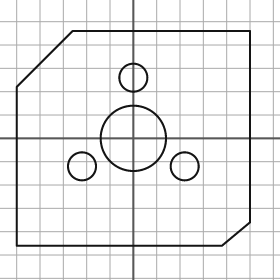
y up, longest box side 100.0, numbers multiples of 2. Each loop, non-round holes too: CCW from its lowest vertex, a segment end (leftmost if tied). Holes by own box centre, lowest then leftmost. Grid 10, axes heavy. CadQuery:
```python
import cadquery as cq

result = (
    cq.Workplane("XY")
    .moveTo(-50.0, -46.0)
    .lineTo(38.0, -46.0)
    .lineTo(50.0, -36.0)
    .lineTo(50.0, 46.0)
    .lineTo(-26.0, 46.0)
    .lineTo(-50.0, 22.0)
    .close()
    .moveTo(-22.0, -12.0)
    .circle(6.0)
    .moveTo(22.0, -12.0)
    .circle(6.0)
    .moveTo(0.0, 0.0)
    .circle(14.0)
    .moveTo(0.0, 26.0)
    .circle(6.0)
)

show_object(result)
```